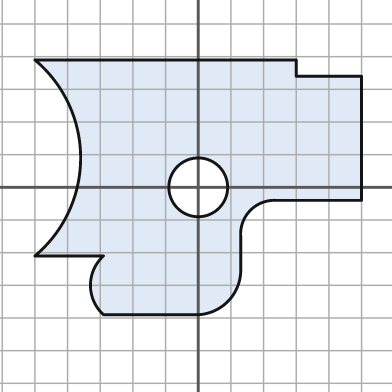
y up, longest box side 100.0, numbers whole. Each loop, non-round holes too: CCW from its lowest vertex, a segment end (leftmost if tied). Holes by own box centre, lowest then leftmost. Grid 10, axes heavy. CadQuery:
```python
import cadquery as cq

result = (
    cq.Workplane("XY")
    .moveTo(-29.0, -39.0)
    .lineTo(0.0, -39.0)
    .threePointArc((9.0, -35.0), (13.0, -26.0))
    .lineTo(13.0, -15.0)
    .threePointArc((16.0, -7.0), (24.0, -4.0))
    .lineTo(50.0, -4.0)
    .lineTo(50.0, 34.0)
    .lineTo(30.0, 34.0)
    .lineTo(30.0, 39.0)
    .lineTo(-50.0, 39.0)
    .threePointArc((-36.0, 9.0), (-50.0, -21.0))
    .lineTo(-29.0, -21.0)
    .threePointArc((-33.0, -30.0), (-29.0, -39.0))
    .close()
    .moveTo(0.0, 0.0)
    .circle(9.0)
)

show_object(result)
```